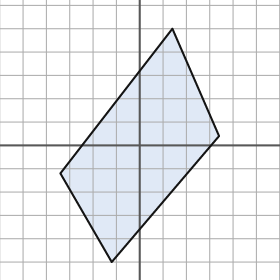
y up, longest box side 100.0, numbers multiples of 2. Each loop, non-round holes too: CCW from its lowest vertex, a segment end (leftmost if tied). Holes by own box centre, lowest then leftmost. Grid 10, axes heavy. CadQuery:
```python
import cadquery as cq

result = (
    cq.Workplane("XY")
    .moveTo(-12.0, -50.0)
    .lineTo(34.0, 4.0)
    .lineTo(14.0, 50.0)
    .lineTo(-34.0, -12.0)
    .close()
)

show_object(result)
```